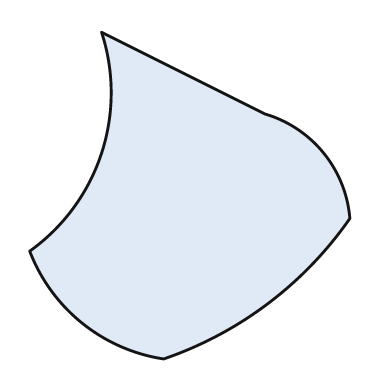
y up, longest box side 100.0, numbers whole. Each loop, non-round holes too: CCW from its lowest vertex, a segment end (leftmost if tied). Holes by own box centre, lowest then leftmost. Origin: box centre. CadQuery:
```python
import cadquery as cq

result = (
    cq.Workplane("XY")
    .moveTo(-8.0, -50.0)
    .threePointArc((24.0, -33.0), (49.0, -7.0))
    .threePointArc((41.0, 13.0), (23.0, 25.0))
    .lineTo(-27.0, 50.0)
    .threePointArc((-27.0, 13.0), (-49.0, -17.0))
    .threePointArc((-33.0, -39.0), (-8.0, -50.0))
    .close()
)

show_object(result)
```